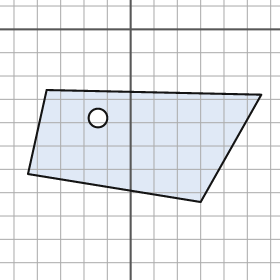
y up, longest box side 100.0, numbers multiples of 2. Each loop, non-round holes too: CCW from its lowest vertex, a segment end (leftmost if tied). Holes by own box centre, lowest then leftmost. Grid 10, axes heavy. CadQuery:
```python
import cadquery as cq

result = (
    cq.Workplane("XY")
    .moveTo(30.0, -74.0)
    .lineTo(56.0, -28.0)
    .lineTo(-36.0, -26.0)
    .lineTo(-44.0, -62.0)
    .close()
    .moveTo(-14.0, -38.0)
    .circle(4.0)
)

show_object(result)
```